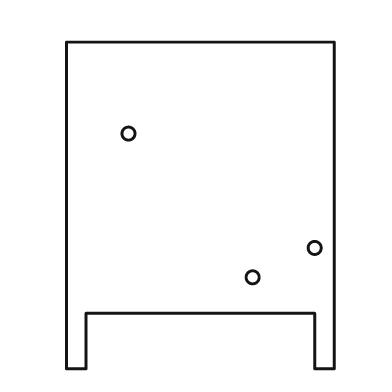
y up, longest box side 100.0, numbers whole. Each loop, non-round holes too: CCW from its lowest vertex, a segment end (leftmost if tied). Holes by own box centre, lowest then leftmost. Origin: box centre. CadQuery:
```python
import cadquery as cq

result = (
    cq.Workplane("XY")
    .moveTo(-41.0, -50.0)
    .lineTo(-35.0, -50.0)
    .lineTo(-35.0, -33.0)
    .lineTo(35.0, -33.0)
    .lineTo(35.0, -50.0)
    .lineTo(41.0, -50.0)
    .lineTo(41.0, 50.0)
    .lineTo(-41.0, 50.0)
    .close()
    .moveTo(16.0, -22.0)
    .circle(2.0)
    .moveTo(35.0, -13.0)
    .circle(2.0)
    .moveTo(-22.0, 22.0)
    .circle(2.0)
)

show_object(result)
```